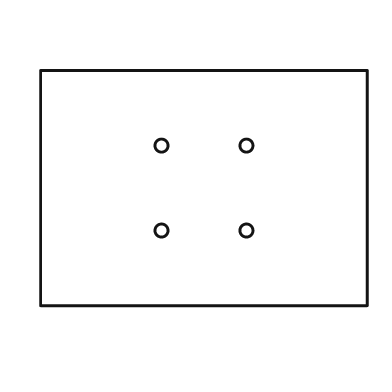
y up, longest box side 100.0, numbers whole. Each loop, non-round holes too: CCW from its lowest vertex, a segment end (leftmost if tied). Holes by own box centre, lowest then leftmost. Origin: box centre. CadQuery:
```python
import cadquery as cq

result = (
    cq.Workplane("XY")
    .moveTo(-50.0, -36.0)
    .lineTo(50.0, -36.0)
    .lineTo(50.0, 36.0)
    .lineTo(-50.0, 36.0)
    .close()
    .moveTo(-13.0, -13.0)
    .circle(2.0)
    .moveTo(13.0, -13.0)
    .circle(2.0)
    .moveTo(-13.0, 13.0)
    .circle(2.0)
    .moveTo(13.0, 13.0)
    .circle(2.0)
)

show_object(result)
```